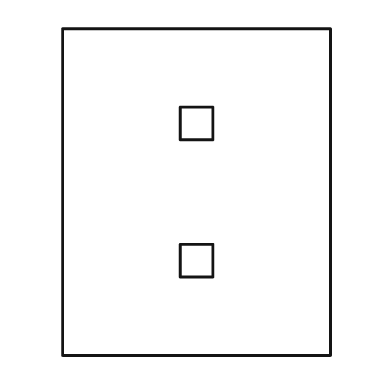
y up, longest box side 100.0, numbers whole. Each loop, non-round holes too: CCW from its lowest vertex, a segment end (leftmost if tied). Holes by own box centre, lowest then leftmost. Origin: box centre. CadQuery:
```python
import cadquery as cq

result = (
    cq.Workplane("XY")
    .moveTo(-41.0, -50.0)
    .lineTo(41.0, -50.0)
    .lineTo(41.0, 50.0)
    .lineTo(-41.0, 50.0)
    .close()
    .moveTo(-5.0, -26.0)
    .lineTo(5.0, -26.0)
    .lineTo(5.0, -16.0)
    .lineTo(-5.0, -16.0)
    .close()
    .moveTo(-5.0, 16.0)
    .lineTo(5.0, 16.0)
    .lineTo(5.0, 26.0)
    .lineTo(-5.0, 26.0)
    .close()
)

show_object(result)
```